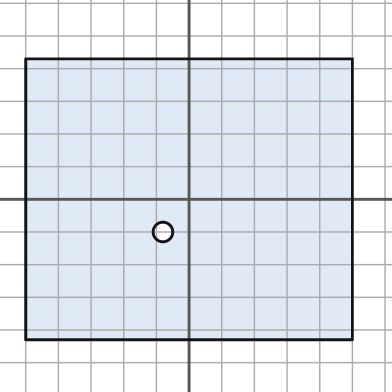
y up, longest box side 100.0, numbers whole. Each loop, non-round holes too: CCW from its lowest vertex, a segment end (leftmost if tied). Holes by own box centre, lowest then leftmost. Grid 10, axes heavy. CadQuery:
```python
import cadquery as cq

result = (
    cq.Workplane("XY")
    .moveTo(-50.0, -43.0)
    .lineTo(50.0, -43.0)
    .lineTo(50.0, 43.0)
    .lineTo(-50.0, 43.0)
    .close()
    .moveTo(-8.0, -10.0)
    .circle(3.0)
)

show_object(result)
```